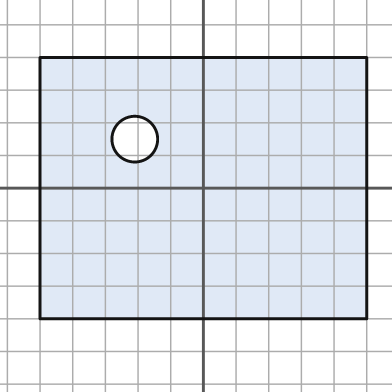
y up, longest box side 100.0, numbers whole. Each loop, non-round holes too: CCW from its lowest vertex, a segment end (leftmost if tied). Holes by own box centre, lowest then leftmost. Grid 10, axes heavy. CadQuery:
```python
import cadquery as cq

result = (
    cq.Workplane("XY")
    .moveTo(-50.0, -40.0)
    .lineTo(50.0, -40.0)
    .lineTo(50.0, 40.0)
    .lineTo(-50.0, 40.0)
    .close()
    .moveTo(-21.0, 15.0)
    .circle(7.0)
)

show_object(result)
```